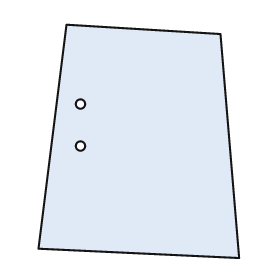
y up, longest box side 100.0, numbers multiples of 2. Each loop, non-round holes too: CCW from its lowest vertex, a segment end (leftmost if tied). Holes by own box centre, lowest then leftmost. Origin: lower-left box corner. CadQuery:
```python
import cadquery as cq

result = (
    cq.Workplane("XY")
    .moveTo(86.0, 0.0)
    .lineTo(78.0, 96.0)
    .lineTo(12.0, 100.0)
    .lineTo(0.0, 4.0)
    .close()
    .moveTo(18.0, 48.0)
    .circle(2.0)
    .moveTo(18.0, 66.0)
    .circle(2.0)
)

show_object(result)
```